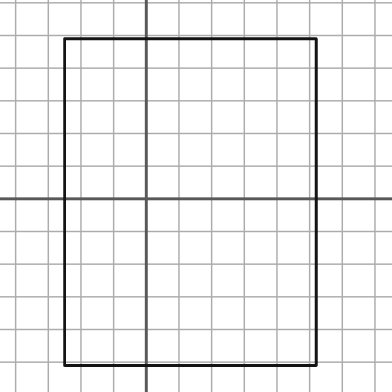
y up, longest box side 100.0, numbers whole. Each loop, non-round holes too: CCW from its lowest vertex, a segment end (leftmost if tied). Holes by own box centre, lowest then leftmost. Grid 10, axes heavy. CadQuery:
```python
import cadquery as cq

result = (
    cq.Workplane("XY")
    .moveTo(-25.0, -51.0)
    .lineTo(52.0, -51.0)
    .lineTo(52.0, 49.0)
    .lineTo(-25.0, 49.0)
    .close()
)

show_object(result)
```